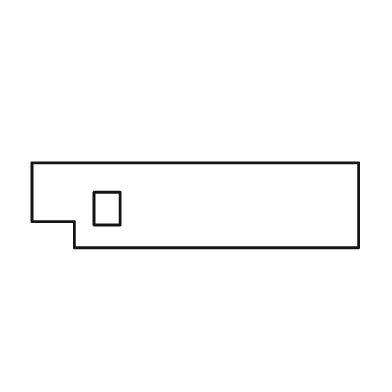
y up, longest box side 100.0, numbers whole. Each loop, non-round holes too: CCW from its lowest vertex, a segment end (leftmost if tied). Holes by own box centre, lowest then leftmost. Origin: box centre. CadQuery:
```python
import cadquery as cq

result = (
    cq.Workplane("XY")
    .moveTo(-37.0, -13.0)
    .lineTo(50.0, -13.0)
    .lineTo(50.0, 13.0)
    .lineTo(-50.0, 13.0)
    .lineTo(-50.0, -5.0)
    .lineTo(-37.0, -5.0)
    .close()
    .moveTo(-31.0, -6.0)
    .lineTo(-23.0, -6.0)
    .lineTo(-23.0, 4.0)
    .lineTo(-31.0, 4.0)
    .close()
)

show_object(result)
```